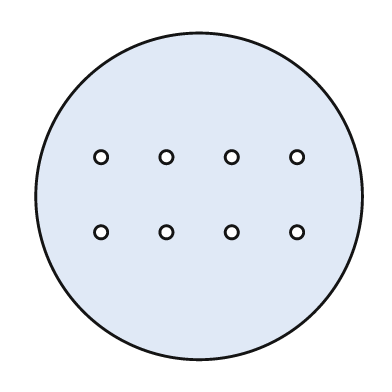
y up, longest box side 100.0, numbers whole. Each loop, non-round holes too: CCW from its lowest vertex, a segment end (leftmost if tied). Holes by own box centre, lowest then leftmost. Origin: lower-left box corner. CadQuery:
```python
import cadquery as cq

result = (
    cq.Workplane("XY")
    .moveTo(50.0, 50.0)
    .circle(50.0)
    .moveTo(20.0, 39.0)
    .circle(2.0)
    .moveTo(40.0, 39.0)
    .circle(2.0)
    .moveTo(60.0, 39.0)
    .circle(2.0)
    .moveTo(80.0, 39.0)
    .circle(2.0)
    .moveTo(20.0, 62.0)
    .circle(2.0)
    .moveTo(40.0, 62.0)
    .circle(2.0)
    .moveTo(60.0, 62.0)
    .circle(2.0)
    .moveTo(80.0, 62.0)
    .circle(2.0)
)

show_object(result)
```